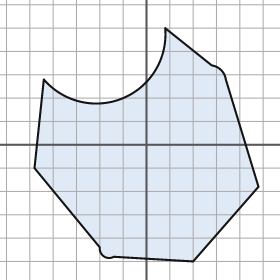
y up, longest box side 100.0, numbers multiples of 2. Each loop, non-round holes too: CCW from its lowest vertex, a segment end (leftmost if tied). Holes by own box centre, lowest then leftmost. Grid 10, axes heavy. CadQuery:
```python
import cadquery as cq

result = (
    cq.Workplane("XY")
    .moveTo(20.0, -50.0)
    .lineTo(48.0, -18.0)
    .lineTo(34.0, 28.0)
    .threePointArc((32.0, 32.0), (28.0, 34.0))
    .lineTo(8.0, 50.0)
    .threePointArc((-10.0, 20.0), (-44.0, 28.0))
    .lineTo(-48.0, -10.0)
    .lineTo(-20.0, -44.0)
    .threePointArc((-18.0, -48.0), (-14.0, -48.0))
    .close()
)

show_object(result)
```